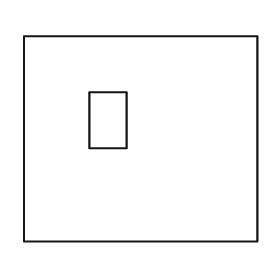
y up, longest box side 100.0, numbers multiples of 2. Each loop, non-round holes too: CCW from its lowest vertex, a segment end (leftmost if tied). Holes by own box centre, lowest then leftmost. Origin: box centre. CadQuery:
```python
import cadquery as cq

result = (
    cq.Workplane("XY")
    .moveTo(-50.0, -44.0)
    .lineTo(50.0, -44.0)
    .lineTo(50.0, 44.0)
    .lineTo(-50.0, 44.0)
    .close()
    .moveTo(-22.0, -4.0)
    .lineTo(-6.0, -4.0)
    .lineTo(-6.0, 20.0)
    .lineTo(-22.0, 20.0)
    .close()
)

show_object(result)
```